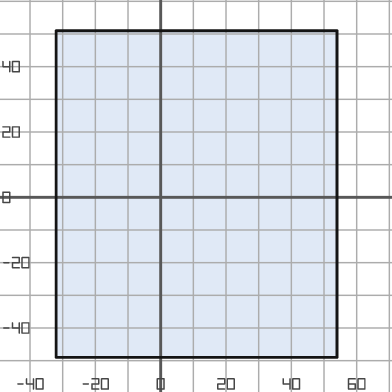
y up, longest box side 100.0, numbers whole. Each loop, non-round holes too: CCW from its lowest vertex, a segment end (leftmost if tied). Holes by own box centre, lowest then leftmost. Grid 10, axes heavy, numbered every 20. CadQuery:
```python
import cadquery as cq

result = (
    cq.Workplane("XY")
    .moveTo(-32.0, -49.0)
    .lineTo(54.0, -49.0)
    .lineTo(54.0, 51.0)
    .lineTo(-32.0, 51.0)
    .close()
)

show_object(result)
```